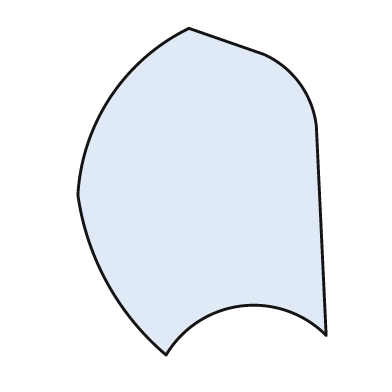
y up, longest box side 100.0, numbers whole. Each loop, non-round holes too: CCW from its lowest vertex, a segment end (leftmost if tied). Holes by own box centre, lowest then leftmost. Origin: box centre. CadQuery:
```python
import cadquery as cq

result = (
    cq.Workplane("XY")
    .moveTo(-11.0, -50.0)
    .threePointArc((12.0, -35.0), (38.0, -44.0))
    .lineTo(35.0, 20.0)
    .threePointArc((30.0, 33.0), (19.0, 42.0))
    .lineTo(-4.0, 50.0)
    .threePointArc((-28.0, 29.0), (-38.0, -1.0))
    .threePointArc((-29.0, -28.0), (-11.0, -50.0))
    .close()
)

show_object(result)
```